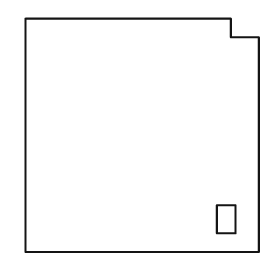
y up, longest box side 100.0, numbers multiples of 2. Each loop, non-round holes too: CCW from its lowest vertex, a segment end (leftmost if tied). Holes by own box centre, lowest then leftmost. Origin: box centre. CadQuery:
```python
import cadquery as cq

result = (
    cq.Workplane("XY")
    .moveTo(-50.0, -50.0)
    .lineTo(50.0, -50.0)
    .lineTo(50.0, 42.0)
    .lineTo(38.0, 42.0)
    .lineTo(38.0, 50.0)
    .lineTo(-50.0, 50.0)
    .close()
    .moveTo(32.0, -42.0)
    .lineTo(40.0, -42.0)
    .lineTo(40.0, -30.0)
    .lineTo(32.0, -30.0)
    .close()
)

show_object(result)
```